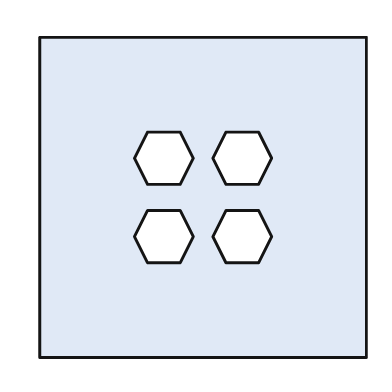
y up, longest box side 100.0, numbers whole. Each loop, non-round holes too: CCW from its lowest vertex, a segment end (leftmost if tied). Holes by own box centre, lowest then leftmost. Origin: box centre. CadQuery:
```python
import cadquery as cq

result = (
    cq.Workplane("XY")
    .moveTo(-50.0, -49.0)
    .lineTo(50.0, -49.0)
    .lineTo(50.0, 49.0)
    .lineTo(-50.0, 49.0)
    .close()
    .moveTo(-17.0, -20.0)
    .lineTo(-7.0, -20.0)
    .lineTo(-3.0, -12.0)
    .lineTo(-7.0, -4.0)
    .lineTo(-17.0, -4.0)
    .lineTo(-21.0, -12.0)
    .close()
    .moveTo(7.0, -20.0)
    .lineTo(17.0, -20.0)
    .lineTo(21.0, -12.0)
    .lineTo(17.0, -4.0)
    .lineTo(7.0, -4.0)
    .lineTo(3.0, -12.0)
    .close()
    .moveTo(-17.0, 4.0)
    .lineTo(-7.0, 4.0)
    .lineTo(-3.0, 12.0)
    .lineTo(-7.0, 20.0)
    .lineTo(-17.0, 20.0)
    .lineTo(-21.0, 12.0)
    .close()
    .moveTo(7.0, 4.0)
    .lineTo(17.0, 4.0)
    .lineTo(21.0, 12.0)
    .lineTo(17.0, 20.0)
    .lineTo(7.0, 20.0)
    .lineTo(3.0, 12.0)
    .close()
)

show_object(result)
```